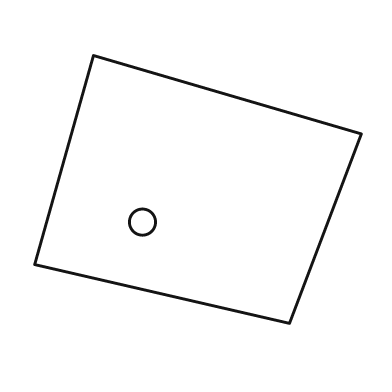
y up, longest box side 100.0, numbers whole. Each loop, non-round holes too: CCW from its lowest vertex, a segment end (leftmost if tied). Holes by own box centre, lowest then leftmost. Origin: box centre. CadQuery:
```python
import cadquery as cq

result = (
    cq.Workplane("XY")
    .moveTo(28.0, -41.0)
    .lineTo(50.0, 17.0)
    .lineTo(-32.0, 41.0)
    .lineTo(-50.0, -23.0)
    .close()
    .moveTo(-17.0, -10.0)
    .circle(4.0)
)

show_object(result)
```